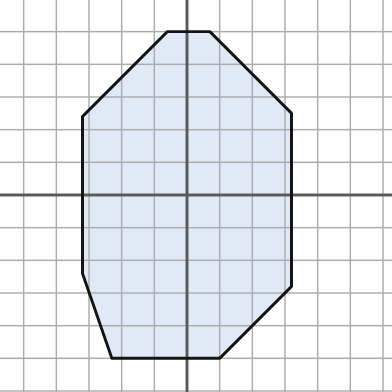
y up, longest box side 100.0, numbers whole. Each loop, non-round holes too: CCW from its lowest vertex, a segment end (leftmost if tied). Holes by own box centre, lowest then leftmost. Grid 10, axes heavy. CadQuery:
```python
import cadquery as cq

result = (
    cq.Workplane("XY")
    .moveTo(-23.0, -50.0)
    .lineTo(10.0, -50.0)
    .lineTo(32.0, -28.0)
    .lineTo(32.0, 25.0)
    .lineTo(7.0, 50.0)
    .lineTo(-6.0, 50.0)
    .lineTo(-32.0, 24.0)
    .lineTo(-32.0, -24.0)
    .close()
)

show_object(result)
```